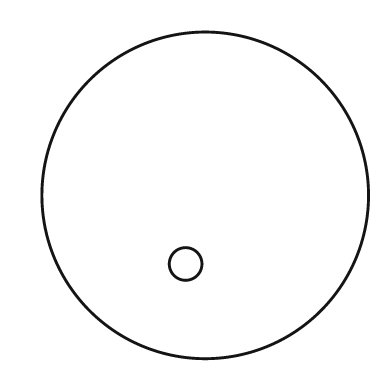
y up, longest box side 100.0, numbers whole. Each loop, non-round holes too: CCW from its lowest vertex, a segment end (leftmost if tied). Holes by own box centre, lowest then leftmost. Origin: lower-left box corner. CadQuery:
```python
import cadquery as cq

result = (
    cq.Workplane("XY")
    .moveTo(50.0, 50.0)
    .circle(50.0)
    .moveTo(44.0, 29.0)
    .circle(5.0)
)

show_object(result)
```